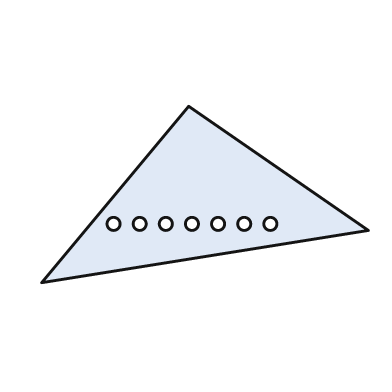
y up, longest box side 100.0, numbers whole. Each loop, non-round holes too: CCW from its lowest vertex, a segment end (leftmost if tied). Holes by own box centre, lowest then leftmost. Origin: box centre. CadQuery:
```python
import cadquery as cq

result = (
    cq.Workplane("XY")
    .moveTo(-50.0, -27.0)
    .lineTo(50.0, -11.0)
    .lineTo(-5.0, 27.0)
    .close()
    .moveTo(-28.0, -9.0)
    .circle(2.0)
    .moveTo(-20.0, -9.0)
    .circle(2.0)
    .moveTo(-12.0, -9.0)
    .circle(2.0)
    .moveTo(-4.0, -9.0)
    .circle(2.0)
    .moveTo(4.0, -9.0)
    .circle(2.0)
    .moveTo(12.0, -9.0)
    .circle(2.0)
    .moveTo(20.0, -9.0)
    .circle(2.0)
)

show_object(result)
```